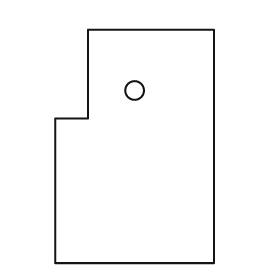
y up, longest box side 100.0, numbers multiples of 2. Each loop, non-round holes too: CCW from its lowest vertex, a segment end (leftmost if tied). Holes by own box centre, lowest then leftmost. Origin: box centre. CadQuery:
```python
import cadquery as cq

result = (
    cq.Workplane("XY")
    .moveTo(-34.0, -50.0)
    .lineTo(34.0, -50.0)
    .lineTo(34.0, 50.0)
    .lineTo(-20.0, 50.0)
    .lineTo(-20.0, 12.0)
    .lineTo(-34.0, 12.0)
    .close()
    .moveTo(0.0, 24.0)
    .circle(4.0)
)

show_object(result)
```